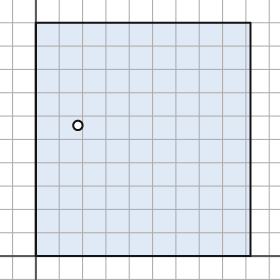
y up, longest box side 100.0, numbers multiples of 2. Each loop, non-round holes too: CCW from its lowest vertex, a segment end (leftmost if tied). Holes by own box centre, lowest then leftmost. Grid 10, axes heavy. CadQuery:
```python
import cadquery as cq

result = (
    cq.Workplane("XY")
    .moveTo(0.0, 0.0)
    .lineTo(92.0, 0.0)
    .lineTo(92.0, 100.0)
    .lineTo(0.0, 100.0)
    .close()
    .moveTo(18.0, 56.0)
    .circle(2.0)
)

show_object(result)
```